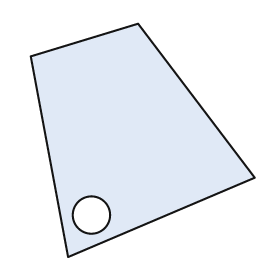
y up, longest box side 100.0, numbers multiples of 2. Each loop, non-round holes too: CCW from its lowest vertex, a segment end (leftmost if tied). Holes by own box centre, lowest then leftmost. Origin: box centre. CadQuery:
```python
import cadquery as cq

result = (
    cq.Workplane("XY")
    .moveTo(-32.0, -50.0)
    .lineTo(48.0, -16.0)
    .lineTo(-2.0, 50.0)
    .lineTo(-48.0, 36.0)
    .close()
    .moveTo(-22.0, -32.0)
    .circle(8.0)
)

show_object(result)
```